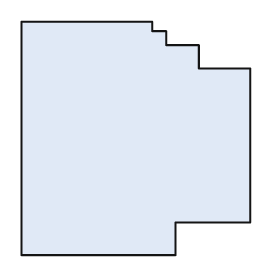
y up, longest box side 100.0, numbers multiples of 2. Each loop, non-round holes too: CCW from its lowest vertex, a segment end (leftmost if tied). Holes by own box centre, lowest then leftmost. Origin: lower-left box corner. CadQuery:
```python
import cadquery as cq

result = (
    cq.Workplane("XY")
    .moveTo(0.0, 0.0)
    .lineTo(66.0, 0.0)
    .lineTo(66.0, 14.0)
    .lineTo(98.0, 14.0)
    .lineTo(98.0, 80.0)
    .lineTo(76.0, 80.0)
    .lineTo(76.0, 90.0)
    .lineTo(62.0, 90.0)
    .lineTo(62.0, 96.0)
    .lineTo(56.0, 96.0)
    .lineTo(56.0, 100.0)
    .lineTo(0.0, 100.0)
    .close()
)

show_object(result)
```